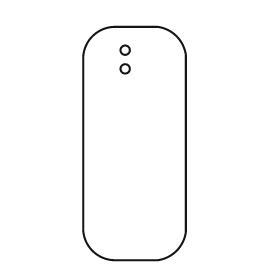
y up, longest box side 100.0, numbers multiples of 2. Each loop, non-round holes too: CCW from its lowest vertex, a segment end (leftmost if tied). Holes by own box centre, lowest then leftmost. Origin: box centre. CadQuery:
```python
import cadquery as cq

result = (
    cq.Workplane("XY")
    .moveTo(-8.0, -50.0)
    .lineTo(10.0, -50.0)
    .threePointArc((18.0, -46.0), (22.0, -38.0))
    .lineTo(22.0, 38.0)
    .threePointArc((18.0, 46.0), (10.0, 50.0))
    .lineTo(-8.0, 50.0)
    .threePointArc((-18.0, 46.0), (-22.0, 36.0))
    .lineTo(-22.0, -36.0)
    .threePointArc((-18.0, -46.0), (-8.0, -50.0))
    .close()
    .moveTo(-4.0, 32.0)
    .circle(2.0)
    .moveTo(-4.0, 40.0)
    .circle(2.0)
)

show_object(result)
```